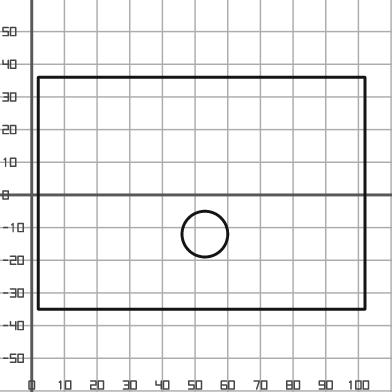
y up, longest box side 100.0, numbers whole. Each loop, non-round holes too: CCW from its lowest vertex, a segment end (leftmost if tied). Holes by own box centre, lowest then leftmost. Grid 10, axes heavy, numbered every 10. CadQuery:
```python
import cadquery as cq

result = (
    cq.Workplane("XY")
    .moveTo(2.0, -35.0)
    .lineTo(102.0, -35.0)
    .lineTo(102.0, 36.0)
    .lineTo(2.0, 36.0)
    .close()
    .moveTo(53.0, -12.0)
    .circle(7.0)
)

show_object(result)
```